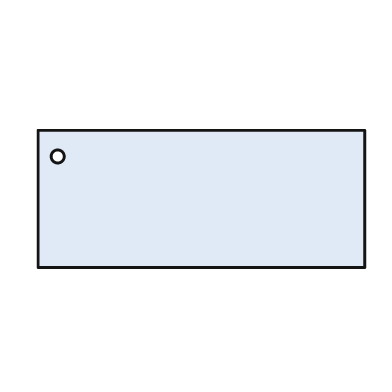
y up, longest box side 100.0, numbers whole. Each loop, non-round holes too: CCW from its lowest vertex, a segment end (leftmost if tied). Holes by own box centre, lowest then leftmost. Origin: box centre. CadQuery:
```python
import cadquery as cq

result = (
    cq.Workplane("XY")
    .moveTo(-50.0, -21.0)
    .lineTo(50.0, -21.0)
    .lineTo(50.0, 21.0)
    .lineTo(-50.0, 21.0)
    .close()
    .moveTo(-44.0, 13.0)
    .circle(2.0)
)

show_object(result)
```